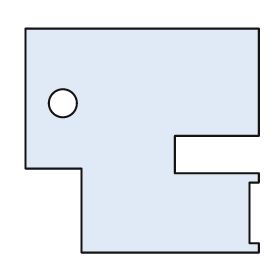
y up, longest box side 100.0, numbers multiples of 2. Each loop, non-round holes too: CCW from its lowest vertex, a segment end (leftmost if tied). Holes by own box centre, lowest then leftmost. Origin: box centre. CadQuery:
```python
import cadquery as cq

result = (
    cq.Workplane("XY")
    .moveTo(-26.0, -48.0)
    .lineTo(50.0, -48.0)
    .lineTo(50.0, -44.0)
    .lineTo(46.0, -44.0)
    .lineTo(46.0, -18.0)
    .lineTo(50.0, -18.0)
    .lineTo(50.0, -14.0)
    .lineTo(14.0, -14.0)
    .lineTo(14.0, 2.0)
    .lineTo(50.0, 2.0)
    .lineTo(50.0, 48.0)
    .lineTo(-50.0, 48.0)
    .lineTo(-50.0, -12.0)
    .lineTo(-26.0, -12.0)
    .close()
    .moveTo(-34.0, 16.0)
    .circle(6.0)
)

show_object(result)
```